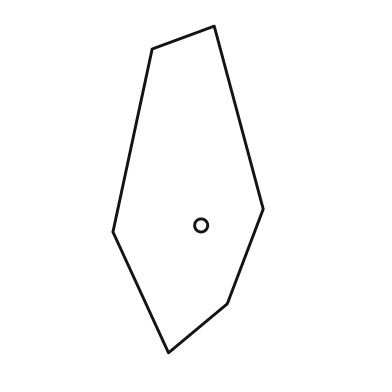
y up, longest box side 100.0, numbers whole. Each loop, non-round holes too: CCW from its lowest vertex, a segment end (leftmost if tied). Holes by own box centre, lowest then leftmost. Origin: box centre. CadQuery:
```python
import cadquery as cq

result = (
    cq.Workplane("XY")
    .moveTo(-6.0, -50.0)
    .lineTo(12.0, -35.0)
    .lineTo(23.0, -6.0)
    .lineTo(8.0, 50.0)
    .lineTo(-11.0, 43.0)
    .lineTo(-23.0, -13.0)
    .close()
    .moveTo(4.0, -11.0)
    .circle(2.0)
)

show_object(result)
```